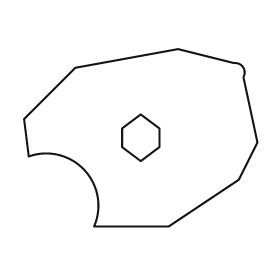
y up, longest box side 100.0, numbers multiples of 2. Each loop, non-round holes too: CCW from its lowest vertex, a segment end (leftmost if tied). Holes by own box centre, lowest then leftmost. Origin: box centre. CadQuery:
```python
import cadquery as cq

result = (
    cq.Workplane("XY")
    .moveTo(-20.0, -38.0)
    .lineTo(12.0, -38.0)
    .lineTo(42.0, -18.0)
    .lineTo(50.0, -2.0)
    .lineTo(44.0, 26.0)
    .threePointArc((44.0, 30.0), (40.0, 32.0))
    .lineTo(16.0, 38.0)
    .lineTo(-28.0, 30.0)
    .lineTo(-50.0, 8.0)
    .lineTo(-48.0, -8.0)
    .threePointArc((-24.0, -14.0), (-20.0, -38.0))
    .close()
    .moveTo(0.0, -10.0)
    .lineTo(8.0, -4.0)
    .lineTo(8.0, 4.0)
    .lineTo(0.0, 10.0)
    .lineTo(-8.0, 4.0)
    .lineTo(-8.0, -4.0)
    .close()
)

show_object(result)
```